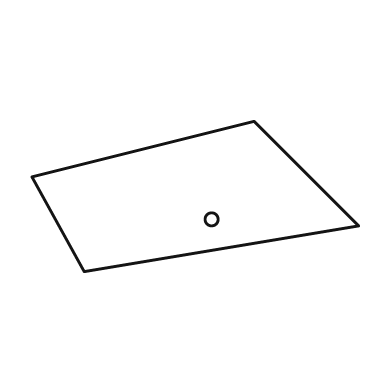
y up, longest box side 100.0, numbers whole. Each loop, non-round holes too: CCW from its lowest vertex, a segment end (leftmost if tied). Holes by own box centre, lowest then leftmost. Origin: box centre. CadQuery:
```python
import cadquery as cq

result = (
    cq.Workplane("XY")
    .moveTo(-34.0, -23.0)
    .lineTo(50.0, -9.0)
    .lineTo(18.0, 23.0)
    .lineTo(-50.0, 6.0)
    .close()
    .moveTo(5.0, -7.0)
    .circle(2.0)
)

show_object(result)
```